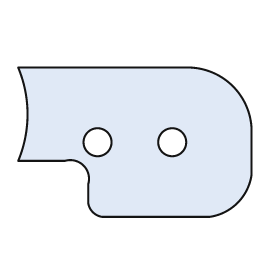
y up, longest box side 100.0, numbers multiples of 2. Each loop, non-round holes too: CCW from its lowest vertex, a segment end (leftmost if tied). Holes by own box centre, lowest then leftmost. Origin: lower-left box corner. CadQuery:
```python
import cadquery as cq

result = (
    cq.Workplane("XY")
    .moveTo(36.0, 0.0)
    .lineTo(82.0, 0.0)
    .threePointArc((94.0, 6.0), (100.0, 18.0))
    .lineTo(100.0, 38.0)
    .threePointArc((92.0, 56.0), (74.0, 64.0))
    .lineTo(0.0, 64.0)
    .threePointArc((4.0, 44.0), (0.0, 24.0))
    .lineTo(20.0, 24.0)
    .threePointArc((28.0, 22.0), (30.0, 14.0))
    .lineTo(30.0, 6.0)
    .threePointArc((32.0, 2.0), (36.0, 0.0))
    .close()
    .moveTo(34.0, 32.0)
    .circle(6.0)
    .moveTo(66.0, 32.0)
    .circle(6.0)
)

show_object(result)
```